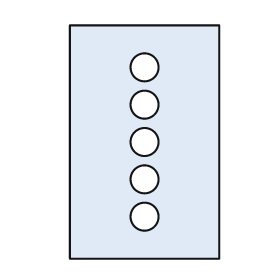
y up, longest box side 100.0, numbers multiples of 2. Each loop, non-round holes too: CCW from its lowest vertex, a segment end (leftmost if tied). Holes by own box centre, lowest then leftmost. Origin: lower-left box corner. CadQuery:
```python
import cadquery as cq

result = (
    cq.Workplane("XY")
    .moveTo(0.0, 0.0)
    .lineTo(64.0, 0.0)
    .lineTo(64.0, 100.0)
    .lineTo(0.0, 100.0)
    .close()
    .moveTo(32.0, 18.0)
    .circle(6.0)
    .moveTo(32.0, 34.0)
    .circle(6.0)
    .moveTo(32.0, 50.0)
    .circle(6.0)
    .moveTo(32.0, 66.0)
    .circle(6.0)
    .moveTo(32.0, 82.0)
    .circle(6.0)
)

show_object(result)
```